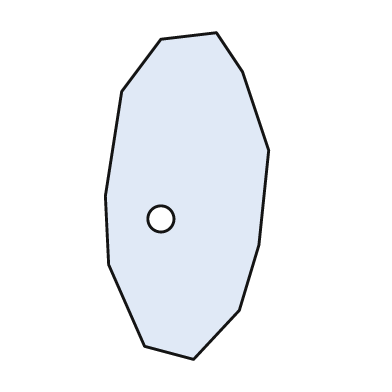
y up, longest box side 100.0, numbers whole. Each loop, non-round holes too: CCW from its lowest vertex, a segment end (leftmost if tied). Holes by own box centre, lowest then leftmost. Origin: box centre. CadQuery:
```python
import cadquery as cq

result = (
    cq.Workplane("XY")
    .moveTo(2.0, -50.0)
    .lineTo(16.0, -35.0)
    .lineTo(22.0, -15.0)
    .lineTo(25.0, 14.0)
    .lineTo(17.0, 38.0)
    .lineTo(9.0, 50.0)
    .lineTo(-8.0, 48.0)
    .lineTo(-20.0, 32.0)
    .lineTo(-25.0, 0.0)
    .lineTo(-24.0, -21.0)
    .lineTo(-13.0, -46.0)
    .close()
    .moveTo(-8.0, -7.0)
    .circle(4.0)
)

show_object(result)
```